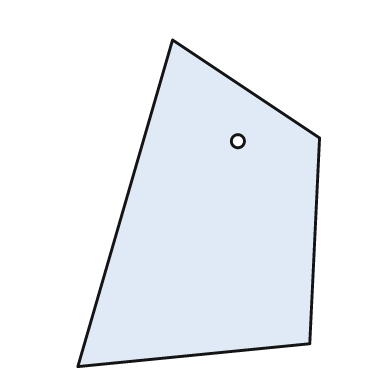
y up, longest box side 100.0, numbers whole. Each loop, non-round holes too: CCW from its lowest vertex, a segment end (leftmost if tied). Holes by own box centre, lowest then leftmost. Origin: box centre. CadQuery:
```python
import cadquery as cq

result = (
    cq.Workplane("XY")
    .moveTo(-37.0, -50.0)
    .lineTo(34.0, -43.0)
    .lineTo(37.0, 20.0)
    .lineTo(-8.0, 50.0)
    .close()
    .moveTo(12.0, 19.0)
    .circle(2.0)
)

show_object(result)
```